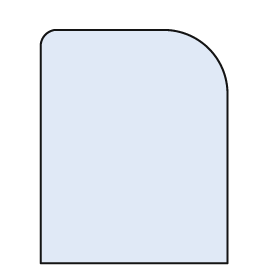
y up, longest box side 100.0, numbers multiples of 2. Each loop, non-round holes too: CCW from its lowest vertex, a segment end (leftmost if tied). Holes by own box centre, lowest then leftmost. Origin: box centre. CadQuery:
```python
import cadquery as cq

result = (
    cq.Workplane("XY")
    .moveTo(-40.0, -50.0)
    .lineTo(40.0, -50.0)
    .lineTo(40.0, 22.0)
    .threePointArc((32.0, 42.0), (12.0, 50.0))
    .lineTo(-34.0, 50.0)
    .threePointArc((-38.0, 48.0), (-40.0, 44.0))
    .close()
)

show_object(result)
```